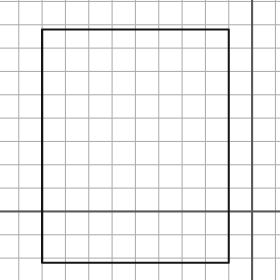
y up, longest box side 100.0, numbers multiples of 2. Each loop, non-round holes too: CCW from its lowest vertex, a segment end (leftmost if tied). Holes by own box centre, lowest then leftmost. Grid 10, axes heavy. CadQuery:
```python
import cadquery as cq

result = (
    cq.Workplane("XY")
    .moveTo(-90.0, -22.0)
    .lineTo(-10.0, -22.0)
    .lineTo(-10.0, 78.0)
    .lineTo(-90.0, 78.0)
    .close()
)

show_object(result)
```